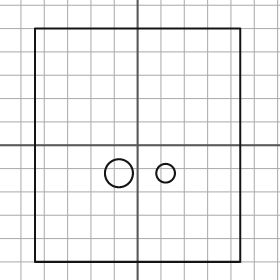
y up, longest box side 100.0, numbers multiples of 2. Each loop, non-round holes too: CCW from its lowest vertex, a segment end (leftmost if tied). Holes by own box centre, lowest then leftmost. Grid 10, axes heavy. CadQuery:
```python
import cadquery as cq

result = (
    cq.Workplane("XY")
    .moveTo(-44.0, -50.0)
    .lineTo(44.0, -50.0)
    .lineTo(44.0, 50.0)
    .lineTo(-44.0, 50.0)
    .close()
    .moveTo(-8.0, -12.0)
    .circle(6.0)
    .moveTo(12.0, -12.0)
    .circle(4.0)
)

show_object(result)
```